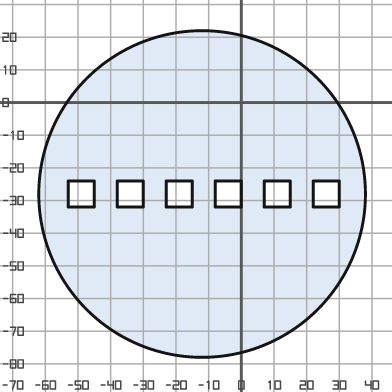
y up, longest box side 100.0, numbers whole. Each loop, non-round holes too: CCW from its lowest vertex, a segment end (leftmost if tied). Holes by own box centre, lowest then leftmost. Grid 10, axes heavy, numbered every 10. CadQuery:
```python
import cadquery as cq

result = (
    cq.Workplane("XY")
    .moveTo(-12.0, -28.0)
    .circle(50.0)
    .moveTo(-53.0, -32.0)
    .lineTo(-45.0, -32.0)
    .lineTo(-45.0, -24.0)
    .lineTo(-53.0, -24.0)
    .close()
    .moveTo(-38.0, -32.0)
    .lineTo(-30.0, -32.0)
    .lineTo(-30.0, -24.0)
    .lineTo(-38.0, -24.0)
    .close()
    .moveTo(-23.0, -32.0)
    .lineTo(-15.0, -32.0)
    .lineTo(-15.0, -24.0)
    .lineTo(-23.0, -24.0)
    .close()
    .moveTo(-8.0, -32.0)
    .lineTo(0.0, -32.0)
    .lineTo(0.0, -24.0)
    .lineTo(-8.0, -24.0)
    .close()
    .moveTo(7.0, -32.0)
    .lineTo(15.0, -32.0)
    .lineTo(15.0, -24.0)
    .lineTo(7.0, -24.0)
    .close()
    .moveTo(22.0, -32.0)
    .lineTo(30.0, -32.0)
    .lineTo(30.0, -24.0)
    .lineTo(22.0, -24.0)
    .close()
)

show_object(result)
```